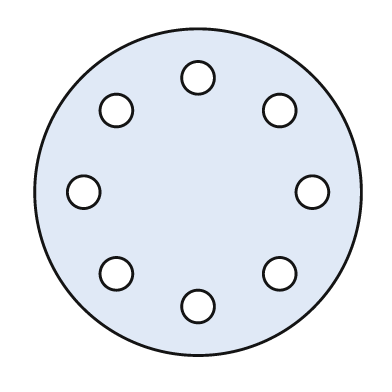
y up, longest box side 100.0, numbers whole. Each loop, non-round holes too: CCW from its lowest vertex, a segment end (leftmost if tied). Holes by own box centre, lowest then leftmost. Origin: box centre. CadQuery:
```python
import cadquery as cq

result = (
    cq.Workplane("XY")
    .moveTo(0.0, 0.0)
    .circle(50.0)
    .moveTo(0.0, -35.0)
    .circle(5.0)
    .moveTo(-25.0, -25.0)
    .circle(5.0)
    .moveTo(25.0, -25.0)
    .circle(5.0)
    .moveTo(-35.0, 0.0)
    .circle(5.0)
    .moveTo(35.0, 0.0)
    .circle(5.0)
    .moveTo(-25.0, 25.0)
    .circle(5.0)
    .moveTo(25.0, 25.0)
    .circle(5.0)
    .moveTo(0.0, 35.0)
    .circle(5.0)
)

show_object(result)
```